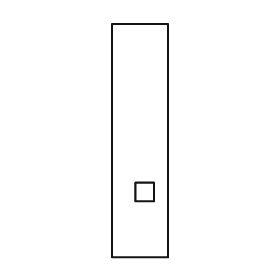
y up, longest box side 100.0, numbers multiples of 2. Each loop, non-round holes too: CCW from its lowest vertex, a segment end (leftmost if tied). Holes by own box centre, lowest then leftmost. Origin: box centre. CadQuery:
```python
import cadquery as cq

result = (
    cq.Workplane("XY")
    .moveTo(-12.0, -50.0)
    .lineTo(12.0, -50.0)
    .lineTo(12.0, 50.0)
    .lineTo(-12.0, 50.0)
    .close()
    .moveTo(-2.0, -26.0)
    .lineTo(6.0, -26.0)
    .lineTo(6.0, -18.0)
    .lineTo(-2.0, -18.0)
    .close()
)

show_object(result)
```